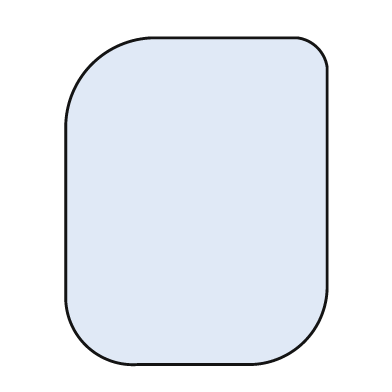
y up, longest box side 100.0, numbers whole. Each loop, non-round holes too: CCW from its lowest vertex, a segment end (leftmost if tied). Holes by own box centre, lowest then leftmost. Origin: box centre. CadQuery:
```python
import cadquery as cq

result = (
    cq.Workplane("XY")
    .moveTo(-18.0, -50.0)
    .lineTo(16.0, -50.0)
    .threePointArc((33.0, -43.0), (40.0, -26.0))
    .lineTo(40.0, 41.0)
    .threePointArc((37.0, 47.0), (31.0, 50.0))
    .lineTo(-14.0, 50.0)
    .threePointArc((-32.0, 42.0), (-40.0, 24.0))
    .lineTo(-40.0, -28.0)
    .threePointArc((-34.0, -44.0), (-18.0, -50.0))
    .close()
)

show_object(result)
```